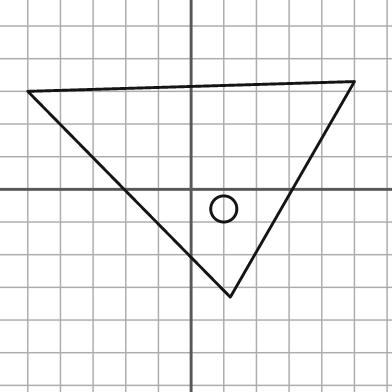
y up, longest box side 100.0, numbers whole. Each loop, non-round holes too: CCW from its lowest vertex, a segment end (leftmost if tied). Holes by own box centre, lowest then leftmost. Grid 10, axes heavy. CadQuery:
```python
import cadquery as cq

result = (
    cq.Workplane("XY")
    .moveTo(12.0, -33.0)
    .lineTo(50.0, 33.0)
    .lineTo(-50.0, 30.0)
    .close()
    .moveTo(10.0, -6.0)
    .circle(4.0)
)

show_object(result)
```